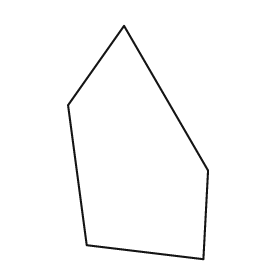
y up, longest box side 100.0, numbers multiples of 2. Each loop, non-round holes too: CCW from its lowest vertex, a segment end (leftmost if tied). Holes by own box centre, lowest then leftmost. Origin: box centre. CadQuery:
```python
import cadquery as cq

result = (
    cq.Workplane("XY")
    .moveTo(28.0, -50.0)
    .lineTo(30.0, -12.0)
    .lineTo(-6.0, 50.0)
    .lineTo(-30.0, 16.0)
    .lineTo(-22.0, -44.0)
    .close()
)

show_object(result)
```